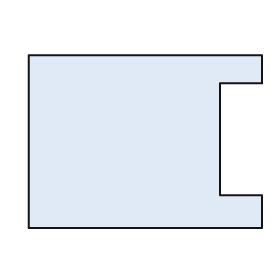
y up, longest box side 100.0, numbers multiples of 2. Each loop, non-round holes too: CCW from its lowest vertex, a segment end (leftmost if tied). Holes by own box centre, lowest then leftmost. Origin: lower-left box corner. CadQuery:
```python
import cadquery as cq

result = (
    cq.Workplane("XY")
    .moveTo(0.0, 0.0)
    .lineTo(100.0, 0.0)
    .lineTo(100.0, 14.0)
    .lineTo(82.0, 14.0)
    .lineTo(82.0, 62.0)
    .lineTo(100.0, 62.0)
    .lineTo(100.0, 74.0)
    .lineTo(0.0, 74.0)
    .close()
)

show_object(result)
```